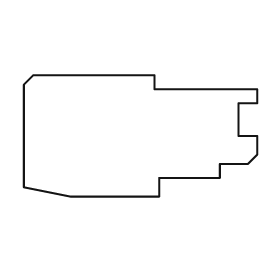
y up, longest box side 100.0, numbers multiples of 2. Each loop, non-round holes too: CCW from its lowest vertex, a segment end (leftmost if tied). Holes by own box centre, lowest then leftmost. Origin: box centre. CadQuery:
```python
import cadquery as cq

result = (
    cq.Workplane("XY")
    .moveTo(-30.0, -26.0)
    .lineTo(8.0, -26.0)
    .lineTo(8.0, -18.0)
    .lineTo(34.0, -18.0)
    .lineTo(34.0, -12.0)
    .lineTo(46.0, -12.0)
    .lineTo(50.0, -8.0)
    .lineTo(50.0, 0.0)
    .lineTo(42.0, 0.0)
    .lineTo(42.0, 14.0)
    .lineTo(50.0, 14.0)
    .lineTo(50.0, 20.0)
    .lineTo(6.0, 20.0)
    .lineTo(6.0, 26.0)
    .lineTo(-46.0, 26.0)
    .lineTo(-50.0, 22.0)
    .lineTo(-50.0, -22.0)
    .close()
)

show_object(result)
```